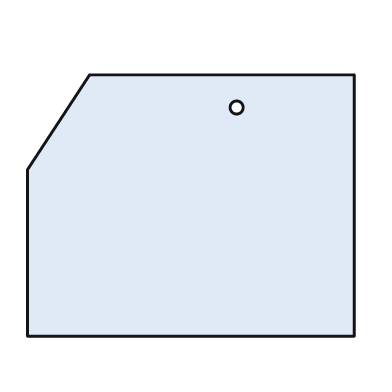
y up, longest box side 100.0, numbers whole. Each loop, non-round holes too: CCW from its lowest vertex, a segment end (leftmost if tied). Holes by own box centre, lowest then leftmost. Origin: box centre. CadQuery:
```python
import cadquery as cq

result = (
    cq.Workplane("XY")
    .moveTo(-50.0, -40.0)
    .lineTo(50.0, -40.0)
    .lineTo(50.0, 40.0)
    .lineTo(-31.0, 40.0)
    .lineTo(-50.0, 11.0)
    .close()
    .moveTo(14.0, 30.0)
    .circle(2.0)
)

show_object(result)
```